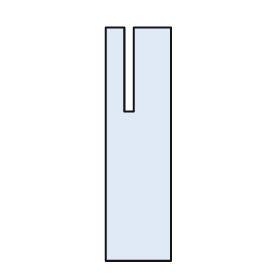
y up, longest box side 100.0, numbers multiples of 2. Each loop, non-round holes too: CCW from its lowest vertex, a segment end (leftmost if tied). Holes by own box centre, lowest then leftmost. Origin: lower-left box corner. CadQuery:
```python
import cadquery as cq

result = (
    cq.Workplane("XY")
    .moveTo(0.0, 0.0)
    .lineTo(28.0, 0.0)
    .lineTo(28.0, 100.0)
    .lineTo(12.0, 100.0)
    .lineTo(12.0, 64.0)
    .lineTo(8.0, 64.0)
    .lineTo(8.0, 100.0)
    .lineTo(0.0, 100.0)
    .close()
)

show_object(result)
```